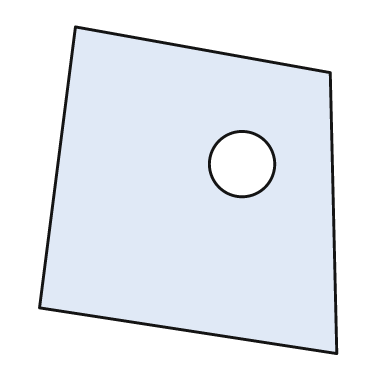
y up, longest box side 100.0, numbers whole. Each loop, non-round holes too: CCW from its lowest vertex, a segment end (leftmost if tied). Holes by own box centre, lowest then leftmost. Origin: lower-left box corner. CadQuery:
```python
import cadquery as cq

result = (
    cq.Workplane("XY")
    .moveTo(91.0, 0.0)
    .lineTo(89.0, 86.0)
    .lineTo(11.0, 100.0)
    .lineTo(0.0, 14.0)
    .close()
    .moveTo(62.0, 58.0)
    .circle(10.0)
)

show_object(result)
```